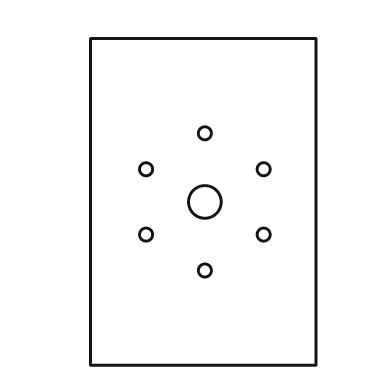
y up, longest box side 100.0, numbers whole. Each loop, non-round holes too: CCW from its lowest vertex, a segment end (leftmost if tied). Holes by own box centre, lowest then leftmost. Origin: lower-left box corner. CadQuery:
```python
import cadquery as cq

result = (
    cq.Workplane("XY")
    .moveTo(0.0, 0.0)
    .lineTo(69.0, 0.0)
    .lineTo(69.0, 100.0)
    .lineTo(0.0, 100.0)
    .close()
    .moveTo(35.0, 29.0)
    .circle(2.0)
    .moveTo(17.0, 40.0)
    .circle(2.0)
    .moveTo(53.0, 40.0)
    .circle(2.0)
    .moveTo(35.0, 50.0)
    .circle(5.0)
    .moveTo(17.0, 60.0)
    .circle(2.0)
    .moveTo(53.0, 60.0)
    .circle(2.0)
    .moveTo(35.0, 71.0)
    .circle(2.0)
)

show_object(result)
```